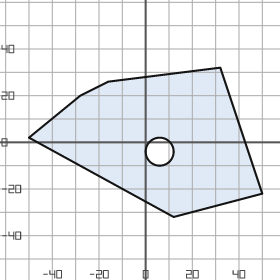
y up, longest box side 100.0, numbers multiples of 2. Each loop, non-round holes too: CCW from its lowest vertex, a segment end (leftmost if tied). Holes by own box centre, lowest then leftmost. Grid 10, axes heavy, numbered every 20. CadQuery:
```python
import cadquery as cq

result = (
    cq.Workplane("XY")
    .moveTo(12.0, -32.0)
    .lineTo(50.0, -22.0)
    .lineTo(32.0, 32.0)
    .lineTo(-16.0, 26.0)
    .lineTo(-28.0, 20.0)
    .lineTo(-50.0, 2.0)
    .close()
    .moveTo(6.0, -4.0)
    .circle(6.0)
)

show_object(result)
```